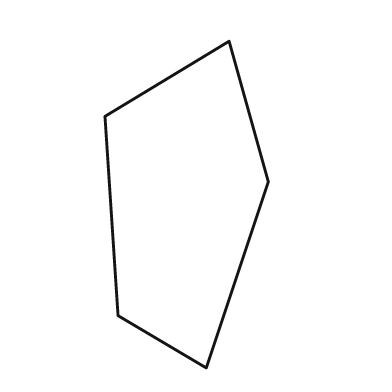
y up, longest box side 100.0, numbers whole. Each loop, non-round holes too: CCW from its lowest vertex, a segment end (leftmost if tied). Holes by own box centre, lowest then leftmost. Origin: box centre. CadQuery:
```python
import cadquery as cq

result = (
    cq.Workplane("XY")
    .moveTo(6.0, -50.0)
    .lineTo(25.0, 7.0)
    .lineTo(13.0, 50.0)
    .lineTo(-25.0, 27.0)
    .lineTo(-21.0, -34.0)
    .close()
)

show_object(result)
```